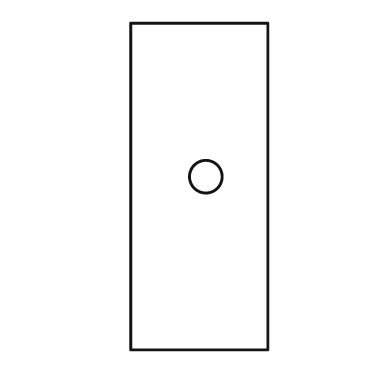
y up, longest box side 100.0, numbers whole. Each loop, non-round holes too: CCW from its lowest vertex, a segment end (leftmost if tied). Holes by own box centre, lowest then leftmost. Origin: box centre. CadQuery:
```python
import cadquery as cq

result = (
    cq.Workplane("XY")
    .moveTo(-21.0, -50.0)
    .lineTo(21.0, -50.0)
    .lineTo(21.0, 50.0)
    .lineTo(-21.0, 50.0)
    .close()
    .moveTo(2.0, 3.0)
    .circle(5.0)
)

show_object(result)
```